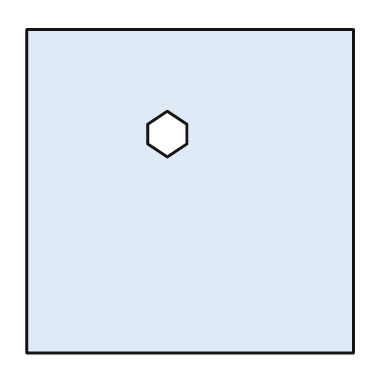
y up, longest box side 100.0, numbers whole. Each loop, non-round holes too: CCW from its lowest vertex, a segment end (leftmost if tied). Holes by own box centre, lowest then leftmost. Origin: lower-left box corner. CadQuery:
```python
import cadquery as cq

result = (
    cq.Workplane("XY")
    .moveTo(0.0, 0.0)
    .lineTo(100.0, 0.0)
    .lineTo(100.0, 99.0)
    .lineTo(0.0, 99.0)
    .close()
    .moveTo(43.0, 60.0)
    .lineTo(49.0, 64.0)
    .lineTo(49.0, 70.0)
    .lineTo(43.0, 74.0)
    .lineTo(37.0, 70.0)
    .lineTo(37.0, 64.0)
    .close()
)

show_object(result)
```